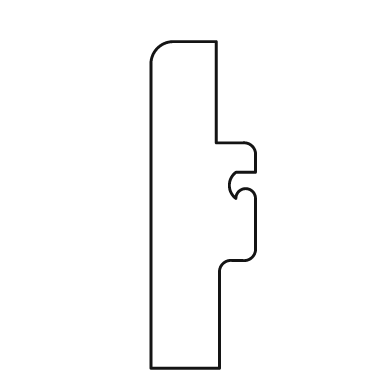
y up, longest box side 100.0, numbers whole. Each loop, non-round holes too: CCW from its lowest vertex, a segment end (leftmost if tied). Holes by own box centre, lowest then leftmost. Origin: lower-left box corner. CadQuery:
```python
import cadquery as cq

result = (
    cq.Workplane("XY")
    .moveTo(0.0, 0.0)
    .lineTo(21.0, 0.0)
    .lineTo(21.0, 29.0)
    .threePointArc((22.0, 32.0), (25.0, 33.0))
    .lineTo(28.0, 33.0)
    .threePointArc((31.0, 34.0), (32.0, 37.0))
    .lineTo(32.0, 52.0)
    .threePointArc((29.0, 55.0), (26.0, 52.0))
    .threePointArc((24.0, 56.0), (26.0, 60.0))
    .lineTo(32.0, 60.0)
    .lineTo(32.0, 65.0)
    .threePointArc((31.0, 68.0), (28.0, 69.0))
    .lineTo(20.0, 69.0)
    .lineTo(20.0, 100.0)
    .lineTo(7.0, 100.0)
    .threePointArc((2.0, 98.0), (0.0, 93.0))
    .close()
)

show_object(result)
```